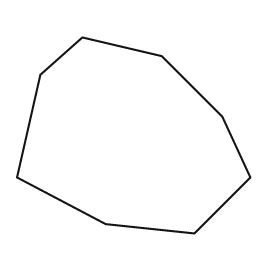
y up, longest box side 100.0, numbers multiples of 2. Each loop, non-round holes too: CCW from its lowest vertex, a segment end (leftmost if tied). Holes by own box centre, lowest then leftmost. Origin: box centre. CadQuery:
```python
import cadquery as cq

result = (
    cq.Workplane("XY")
    .moveTo(26.0, -42.0)
    .lineTo(50.0, -18.0)
    .lineTo(38.0, 8.0)
    .lineTo(12.0, 34.0)
    .lineTo(-22.0, 42.0)
    .lineTo(-40.0, 26.0)
    .lineTo(-50.0, -18.0)
    .lineTo(-12.0, -38.0)
    .close()
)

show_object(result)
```